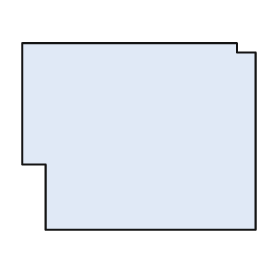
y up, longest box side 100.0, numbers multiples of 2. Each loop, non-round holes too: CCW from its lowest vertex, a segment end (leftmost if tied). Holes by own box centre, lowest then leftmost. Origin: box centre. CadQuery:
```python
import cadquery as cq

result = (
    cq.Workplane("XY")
    .moveTo(-40.0, -40.0)
    .lineTo(50.0, -40.0)
    .lineTo(50.0, 36.0)
    .lineTo(42.0, 36.0)
    .lineTo(42.0, 40.0)
    .lineTo(-50.0, 40.0)
    .lineTo(-50.0, -12.0)
    .lineTo(-40.0, -12.0)
    .close()
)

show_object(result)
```